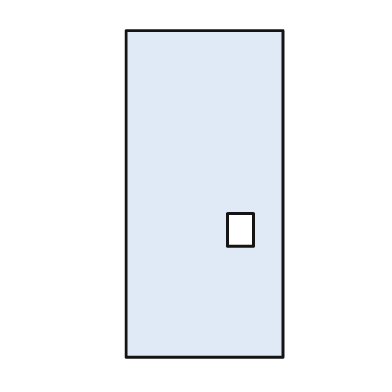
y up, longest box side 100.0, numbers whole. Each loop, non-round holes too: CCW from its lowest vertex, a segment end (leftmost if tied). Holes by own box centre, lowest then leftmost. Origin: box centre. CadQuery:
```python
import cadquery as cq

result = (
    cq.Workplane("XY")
    .moveTo(-24.0, -50.0)
    .lineTo(24.0, -50.0)
    .lineTo(24.0, 50.0)
    .lineTo(-24.0, 50.0)
    .close()
    .moveTo(7.0, -16.0)
    .lineTo(15.0, -16.0)
    .lineTo(15.0, -6.0)
    .lineTo(7.0, -6.0)
    .close()
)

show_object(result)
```